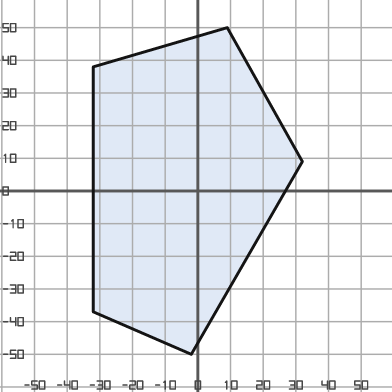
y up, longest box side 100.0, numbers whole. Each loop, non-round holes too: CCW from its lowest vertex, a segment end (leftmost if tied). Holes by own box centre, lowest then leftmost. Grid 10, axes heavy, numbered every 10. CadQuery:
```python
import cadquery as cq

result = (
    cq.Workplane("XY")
    .moveTo(-2.0, -50.0)
    .lineTo(32.0, 9.0)
    .lineTo(9.0, 50.0)
    .lineTo(-32.0, 38.0)
    .lineTo(-32.0, -37.0)
    .close()
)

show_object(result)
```